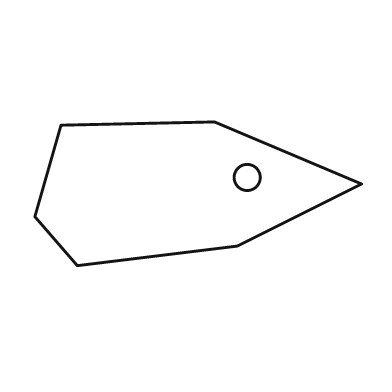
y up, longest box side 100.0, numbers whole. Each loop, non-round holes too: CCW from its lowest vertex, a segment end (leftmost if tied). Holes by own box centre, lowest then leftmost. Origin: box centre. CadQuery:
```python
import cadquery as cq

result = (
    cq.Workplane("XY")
    .moveTo(-37.0, -22.0)
    .lineTo(12.0, -16.0)
    .lineTo(50.0, 3.0)
    .lineTo(5.0, 22.0)
    .lineTo(-42.0, 21.0)
    .lineTo(-50.0, -7.0)
    .close()
    .moveTo(15.0, 5.0)
    .circle(4.0)
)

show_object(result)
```